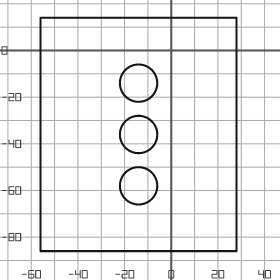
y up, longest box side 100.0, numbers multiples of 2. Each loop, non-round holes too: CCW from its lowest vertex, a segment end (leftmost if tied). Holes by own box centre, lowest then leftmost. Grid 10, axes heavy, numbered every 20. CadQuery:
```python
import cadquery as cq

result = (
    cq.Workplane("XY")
    .moveTo(-56.0, -86.0)
    .lineTo(28.0, -86.0)
    .lineTo(28.0, 14.0)
    .lineTo(-56.0, 14.0)
    .close()
    .moveTo(-14.0, -58.0)
    .circle(8.0)
    .moveTo(-14.0, -36.0)
    .circle(8.0)
    .moveTo(-14.0, -14.0)
    .circle(8.0)
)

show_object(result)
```